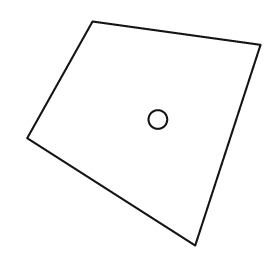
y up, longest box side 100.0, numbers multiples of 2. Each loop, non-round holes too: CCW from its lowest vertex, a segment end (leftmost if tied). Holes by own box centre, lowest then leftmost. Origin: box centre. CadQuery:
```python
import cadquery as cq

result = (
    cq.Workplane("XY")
    .moveTo(22.0, -48.0)
    .lineTo(50.0, 38.0)
    .lineTo(-22.0, 48.0)
    .lineTo(-50.0, -2.0)
    .close()
    .moveTo(6.0, 6.0)
    .circle(4.0)
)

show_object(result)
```